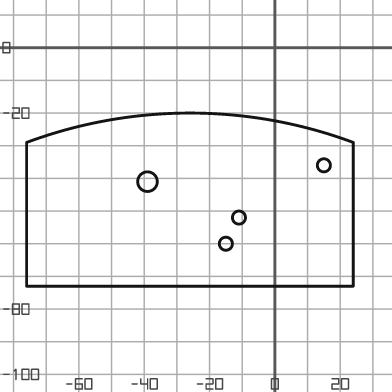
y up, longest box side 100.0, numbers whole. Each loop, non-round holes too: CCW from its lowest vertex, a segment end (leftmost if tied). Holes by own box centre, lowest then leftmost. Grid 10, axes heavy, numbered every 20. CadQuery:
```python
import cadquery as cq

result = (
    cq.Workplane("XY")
    .moveTo(-76.0, -73.0)
    .lineTo(24.0, -73.0)
    .lineTo(24.0, -29.0)
    .threePointArc((-26.0, -20.0), (-76.0, -29.0))
    .close()
    .moveTo(-15.0, -60.0)
    .circle(2.0)
    .moveTo(-11.0, -52.0)
    .circle(2.0)
    .moveTo(-39.0, -41.0)
    .circle(3.0)
    .moveTo(15.0, -36.0)
    .circle(2.0)
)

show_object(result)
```